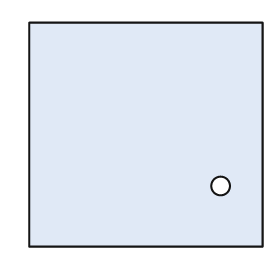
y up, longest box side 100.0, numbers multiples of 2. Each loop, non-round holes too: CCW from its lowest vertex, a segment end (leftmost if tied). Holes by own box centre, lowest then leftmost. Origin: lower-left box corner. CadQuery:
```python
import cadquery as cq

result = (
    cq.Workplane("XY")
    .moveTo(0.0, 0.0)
    .lineTo(100.0, 0.0)
    .lineTo(100.0, 96.0)
    .lineTo(0.0, 96.0)
    .close()
    .moveTo(82.0, 26.0)
    .circle(4.0)
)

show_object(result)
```